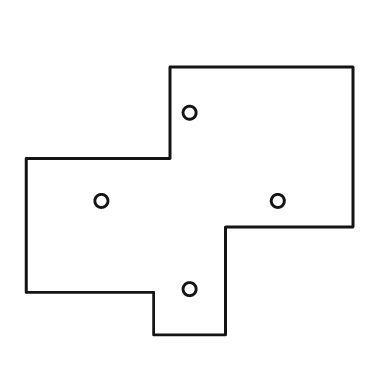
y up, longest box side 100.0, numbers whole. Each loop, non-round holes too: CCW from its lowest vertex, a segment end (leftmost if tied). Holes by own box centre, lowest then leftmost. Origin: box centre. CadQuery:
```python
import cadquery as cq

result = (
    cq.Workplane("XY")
    .moveTo(-11.0, -41.0)
    .lineTo(11.0, -41.0)
    .lineTo(11.0, -8.0)
    .lineTo(50.0, -8.0)
    .lineTo(50.0, 41.0)
    .lineTo(-6.0, 41.0)
    .lineTo(-6.0, 13.0)
    .lineTo(-50.0, 13.0)
    .lineTo(-50.0, -28.0)
    .lineTo(-11.0, -28.0)
    .close()
    .moveTo(0.0, -27.0)
    .circle(2.0)
    .moveTo(-27.0, 0.0)
    .circle(2.0)
    .moveTo(27.0, 0.0)
    .circle(2.0)
    .moveTo(0.0, 27.0)
    .circle(2.0)
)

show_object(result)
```